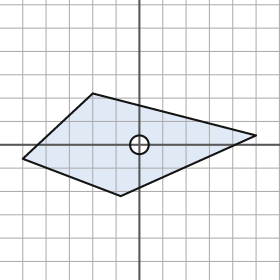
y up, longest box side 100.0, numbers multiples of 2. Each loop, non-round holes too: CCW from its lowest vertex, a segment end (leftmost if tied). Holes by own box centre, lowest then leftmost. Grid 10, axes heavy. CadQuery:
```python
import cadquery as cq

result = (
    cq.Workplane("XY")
    .moveTo(-8.0, -22.0)
    .lineTo(50.0, 4.0)
    .lineTo(-20.0, 22.0)
    .lineTo(-50.0, -6.0)
    .close()
    .moveTo(0.0, 0.0)
    .circle(4.0)
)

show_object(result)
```